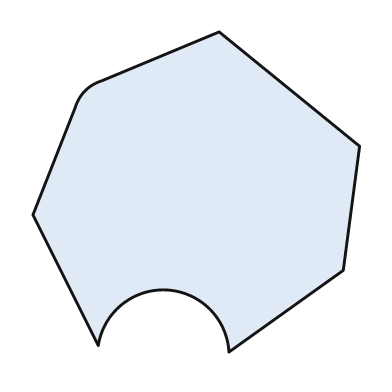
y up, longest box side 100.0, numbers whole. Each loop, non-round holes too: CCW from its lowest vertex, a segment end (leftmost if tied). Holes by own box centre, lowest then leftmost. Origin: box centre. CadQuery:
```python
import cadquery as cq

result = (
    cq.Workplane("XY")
    .moveTo(10.0, -49.0)
    .lineTo(45.0, -24.0)
    .lineTo(50.0, 14.0)
    .lineTo(7.0, 49.0)
    .lineTo(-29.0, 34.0)
    .threePointArc((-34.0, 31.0), (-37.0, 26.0))
    .lineTo(-50.0, -7.0)
    .lineTo(-30.0, -47.0)
    .threePointArc((-9.0, -30.0), (10.0, -49.0))
    .close()
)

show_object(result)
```